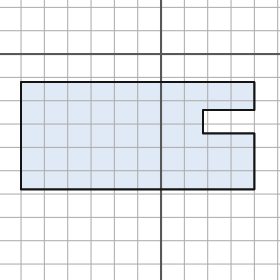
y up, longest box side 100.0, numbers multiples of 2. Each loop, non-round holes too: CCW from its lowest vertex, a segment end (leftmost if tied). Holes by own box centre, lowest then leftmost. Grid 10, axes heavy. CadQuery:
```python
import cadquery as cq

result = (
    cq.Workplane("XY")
    .moveTo(-60.0, -58.0)
    .lineTo(40.0, -58.0)
    .lineTo(40.0, -34.0)
    .lineTo(18.0, -34.0)
    .lineTo(18.0, -24.0)
    .lineTo(40.0, -24.0)
    .lineTo(40.0, -12.0)
    .lineTo(-60.0, -12.0)
    .close()
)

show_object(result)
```